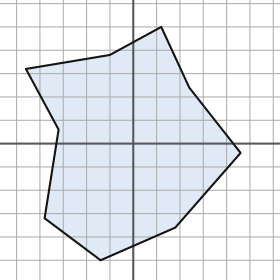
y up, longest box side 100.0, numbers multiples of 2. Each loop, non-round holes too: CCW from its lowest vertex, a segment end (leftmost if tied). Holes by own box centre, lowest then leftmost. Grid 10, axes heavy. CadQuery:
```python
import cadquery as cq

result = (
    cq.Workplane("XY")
    .moveTo(-14.0, -50.0)
    .lineTo(18.0, -36.0)
    .lineTo(46.0, -4.0)
    .lineTo(24.0, 24.0)
    .lineTo(12.0, 50.0)
    .lineTo(-10.0, 38.0)
    .lineTo(-46.0, 32.0)
    .lineTo(-32.0, 6.0)
    .lineTo(-38.0, -32.0)
    .close()
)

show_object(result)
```